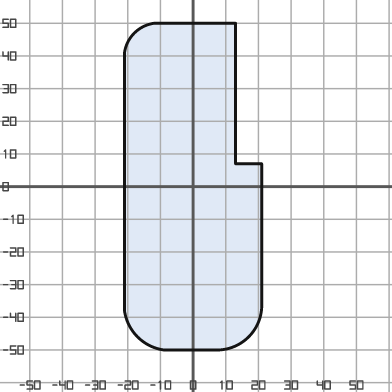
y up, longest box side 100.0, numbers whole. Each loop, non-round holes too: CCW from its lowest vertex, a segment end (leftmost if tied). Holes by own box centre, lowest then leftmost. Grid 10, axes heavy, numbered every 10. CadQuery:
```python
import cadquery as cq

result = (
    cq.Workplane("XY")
    .moveTo(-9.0, -50.0)
    .lineTo(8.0, -50.0)
    .threePointArc((17.0, -46.0), (21.0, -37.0))
    .lineTo(21.0, 7.0)
    .lineTo(13.0, 7.0)
    .lineTo(13.0, 50.0)
    .lineTo(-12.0, 50.0)
    .threePointArc((-18.0, 47.0), (-21.0, 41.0))
    .lineTo(-21.0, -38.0)
    .threePointArc((-17.0, -46.0), (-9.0, -50.0))
    .close()
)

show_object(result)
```